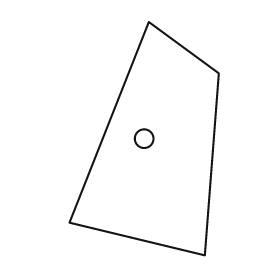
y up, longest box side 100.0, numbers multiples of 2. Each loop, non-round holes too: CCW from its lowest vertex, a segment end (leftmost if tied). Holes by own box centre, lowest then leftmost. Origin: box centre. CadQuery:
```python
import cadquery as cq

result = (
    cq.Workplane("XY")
    .moveTo(26.0, -50.0)
    .lineTo(32.0, 28.0)
    .lineTo(2.0, 50.0)
    .lineTo(-32.0, -36.0)
    .close()
    .moveTo(0.0, 0.0)
    .circle(4.0)
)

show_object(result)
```